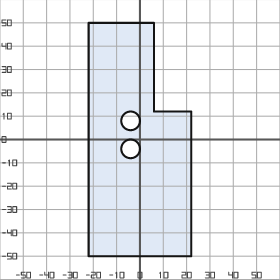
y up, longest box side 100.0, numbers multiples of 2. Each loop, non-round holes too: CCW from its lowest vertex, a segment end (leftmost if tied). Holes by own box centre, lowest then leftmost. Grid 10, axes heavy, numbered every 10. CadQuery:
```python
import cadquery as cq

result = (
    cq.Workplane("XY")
    .moveTo(-22.0, -50.0)
    .lineTo(22.0, -50.0)
    .lineTo(22.0, 12.0)
    .lineTo(6.0, 12.0)
    .lineTo(6.0, 50.0)
    .lineTo(-22.0, 50.0)
    .close()
    .moveTo(-4.0, -4.0)
    .circle(4.0)
    .moveTo(-4.0, 8.0)
    .circle(4.0)
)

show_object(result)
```